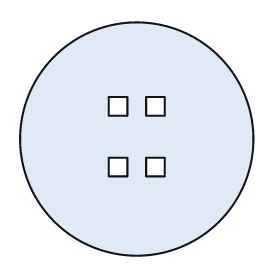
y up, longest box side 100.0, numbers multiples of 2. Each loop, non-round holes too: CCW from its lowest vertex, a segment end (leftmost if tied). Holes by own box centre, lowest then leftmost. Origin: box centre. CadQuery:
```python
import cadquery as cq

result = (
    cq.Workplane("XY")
    .moveTo(0.0, 0.0)
    .circle(50.0)
    .moveTo(-12.0, -16.0)
    .lineTo(-4.0, -16.0)
    .lineTo(-4.0, -8.0)
    .lineTo(-12.0, -8.0)
    .close()
    .moveTo(4.0, -16.0)
    .lineTo(12.0, -16.0)
    .lineTo(12.0, -8.0)
    .lineTo(4.0, -8.0)
    .close()
    .moveTo(-12.0, 10.0)
    .lineTo(-4.0, 10.0)
    .lineTo(-4.0, 18.0)
    .lineTo(-12.0, 18.0)
    .close()
    .moveTo(4.0, 10.0)
    .lineTo(12.0, 10.0)
    .lineTo(12.0, 18.0)
    .lineTo(4.0, 18.0)
    .close()
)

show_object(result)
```